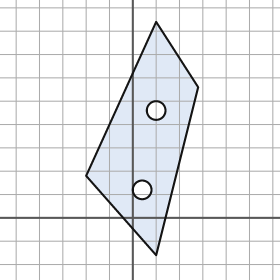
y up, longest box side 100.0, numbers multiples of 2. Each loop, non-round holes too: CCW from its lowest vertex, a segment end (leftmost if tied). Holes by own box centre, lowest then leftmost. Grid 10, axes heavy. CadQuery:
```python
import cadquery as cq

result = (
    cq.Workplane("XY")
    .moveTo(10.0, -16.0)
    .lineTo(28.0, 56.0)
    .lineTo(10.0, 84.0)
    .lineTo(-20.0, 18.0)
    .close()
    .moveTo(4.0, 12.0)
    .circle(4.0)
    .moveTo(10.0, 46.0)
    .circle(4.0)
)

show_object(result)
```